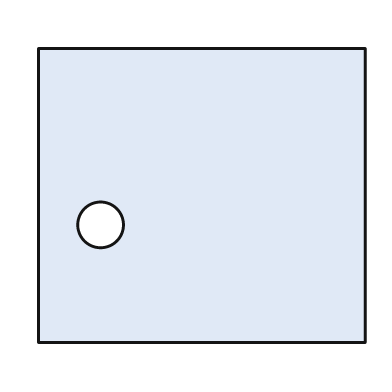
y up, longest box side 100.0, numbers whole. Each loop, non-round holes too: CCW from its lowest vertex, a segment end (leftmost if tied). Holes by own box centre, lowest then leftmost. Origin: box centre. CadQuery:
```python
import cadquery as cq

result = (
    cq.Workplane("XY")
    .moveTo(-50.0, -45.0)
    .lineTo(50.0, -45.0)
    .lineTo(50.0, 45.0)
    .lineTo(-50.0, 45.0)
    .close()
    .moveTo(-31.0, -9.0)
    .circle(7.0)
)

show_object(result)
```